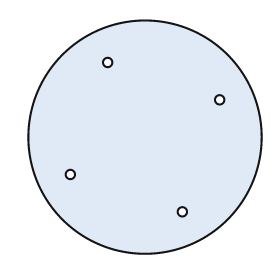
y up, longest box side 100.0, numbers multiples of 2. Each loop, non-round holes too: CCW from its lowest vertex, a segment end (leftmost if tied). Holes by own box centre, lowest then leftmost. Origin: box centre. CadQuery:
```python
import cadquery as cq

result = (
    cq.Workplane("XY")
    .moveTo(0.0, 0.0)
    .circle(50.0)
    .moveTo(16.0, -32.0)
    .circle(2.0)
    .moveTo(-32.0, -16.0)
    .circle(2.0)
    .moveTo(32.0, 16.0)
    .circle(2.0)
    .moveTo(-16.0, 32.0)
    .circle(2.0)
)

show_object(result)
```